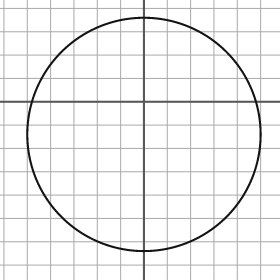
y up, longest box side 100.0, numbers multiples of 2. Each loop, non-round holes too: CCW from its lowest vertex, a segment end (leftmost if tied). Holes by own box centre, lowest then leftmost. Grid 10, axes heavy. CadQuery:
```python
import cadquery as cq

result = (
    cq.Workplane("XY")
    .moveTo(0.0, -14.0)
    .circle(50.0)
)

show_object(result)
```